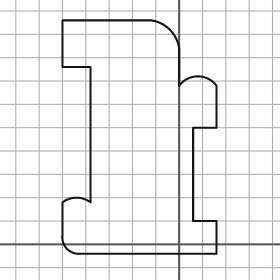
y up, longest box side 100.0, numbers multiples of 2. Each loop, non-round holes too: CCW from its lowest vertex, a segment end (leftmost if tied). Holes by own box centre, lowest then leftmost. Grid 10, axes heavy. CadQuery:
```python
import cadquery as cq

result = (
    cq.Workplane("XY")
    .moveTo(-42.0, -4.0)
    .lineTo(16.0, -4.0)
    .lineTo(16.0, 10.0)
    .lineTo(6.0, 10.0)
    .lineTo(6.0, 50.0)
    .lineTo(16.0, 50.0)
    .lineTo(16.0, 68.0)
    .threePointArc((8.0, 72.0), (0.0, 68.0))
    .lineTo(0.0, 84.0)
    .threePointArc((-4.0, 92.0), (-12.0, 96.0))
    .lineTo(-50.0, 96.0)
    .lineTo(-50.0, 76.0)
    .lineTo(-38.0, 76.0)
    .lineTo(-38.0, 18.0)
    .threePointArc((-44.0, 20.0), (-50.0, 18.0))
    .lineTo(-50.0, 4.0)
    .threePointArc((-48.0, -2.0), (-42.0, -4.0))
    .close()
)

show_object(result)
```